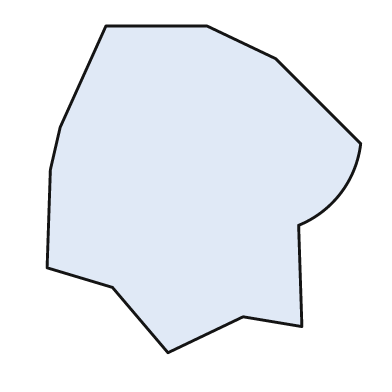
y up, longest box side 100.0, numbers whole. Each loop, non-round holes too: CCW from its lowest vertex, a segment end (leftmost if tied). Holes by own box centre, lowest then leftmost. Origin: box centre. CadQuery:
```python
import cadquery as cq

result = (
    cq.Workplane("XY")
    .moveTo(-11.0, -50.0)
    .lineTo(12.0, -39.0)
    .lineTo(30.0, -42.0)
    .lineTo(29.0, -11.0)
    .threePointArc((42.0, -1.0), (48.0, 14.0))
    .lineTo(22.0, 40.0)
    .lineTo(1.0, 50.0)
    .lineTo(-30.0, 50.0)
    .lineTo(-44.0, 19.0)
    .lineTo(-47.0, 6.0)
    .lineTo(-48.0, -24.0)
    .lineTo(-28.0, -30.0)
    .close()
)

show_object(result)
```